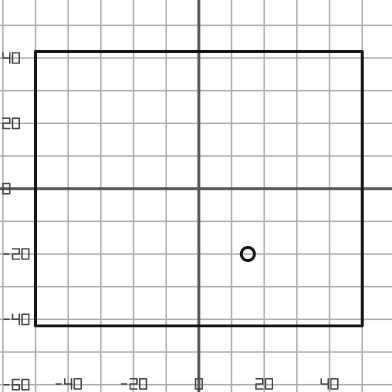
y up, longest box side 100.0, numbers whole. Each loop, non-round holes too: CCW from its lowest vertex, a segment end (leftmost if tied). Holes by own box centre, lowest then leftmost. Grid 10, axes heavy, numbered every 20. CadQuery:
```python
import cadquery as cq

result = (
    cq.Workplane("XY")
    .moveTo(-50.0, -42.0)
    .lineTo(50.0, -42.0)
    .lineTo(50.0, 42.0)
    .lineTo(-50.0, 42.0)
    .close()
    .moveTo(15.0, -20.0)
    .circle(2.0)
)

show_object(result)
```